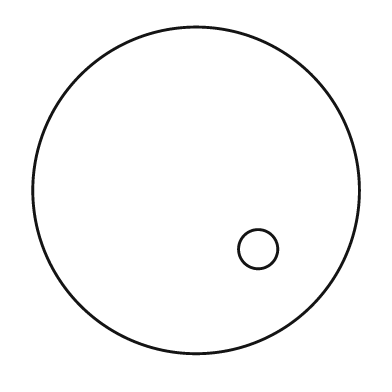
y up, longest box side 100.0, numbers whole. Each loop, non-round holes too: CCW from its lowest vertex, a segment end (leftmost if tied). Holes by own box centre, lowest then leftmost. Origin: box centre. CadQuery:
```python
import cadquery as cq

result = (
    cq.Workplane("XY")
    .moveTo(0.0, 0.0)
    .circle(50.0)
    .moveTo(19.0, -18.0)
    .circle(6.0)
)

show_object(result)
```